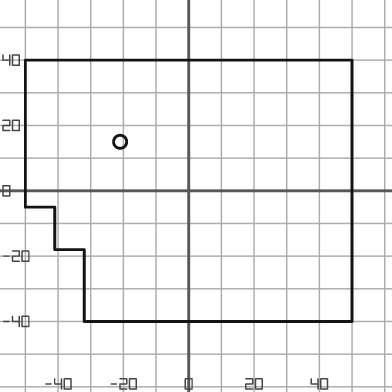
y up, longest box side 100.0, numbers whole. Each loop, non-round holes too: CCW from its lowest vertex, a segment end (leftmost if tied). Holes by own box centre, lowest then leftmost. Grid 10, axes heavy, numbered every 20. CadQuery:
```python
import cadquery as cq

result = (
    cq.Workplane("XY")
    .moveTo(-32.0, -40.0)
    .lineTo(50.0, -40.0)
    .lineTo(50.0, 40.0)
    .lineTo(-50.0, 40.0)
    .lineTo(-50.0, -5.0)
    .lineTo(-41.0, -5.0)
    .lineTo(-41.0, -18.0)
    .lineTo(-32.0, -18.0)
    .close()
    .moveTo(-21.0, 15.0)
    .circle(2.0)
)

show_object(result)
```